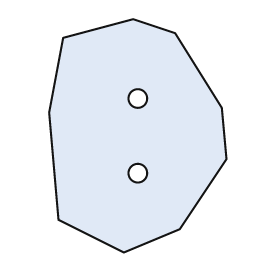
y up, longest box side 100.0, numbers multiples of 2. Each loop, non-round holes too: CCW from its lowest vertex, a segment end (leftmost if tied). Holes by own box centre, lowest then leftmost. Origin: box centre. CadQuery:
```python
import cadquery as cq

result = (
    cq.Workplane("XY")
    .moveTo(-6.0, -50.0)
    .lineTo(18.0, -40.0)
    .lineTo(38.0, -10.0)
    .lineTo(36.0, 12.0)
    .lineTo(16.0, 44.0)
    .lineTo(-2.0, 50.0)
    .lineTo(-32.0, 42.0)
    .lineTo(-38.0, 10.0)
    .lineTo(-34.0, -36.0)
    .close()
    .moveTo(0.0, -16.0)
    .circle(4.0)
    .moveTo(0.0, 16.0)
    .circle(4.0)
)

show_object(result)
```